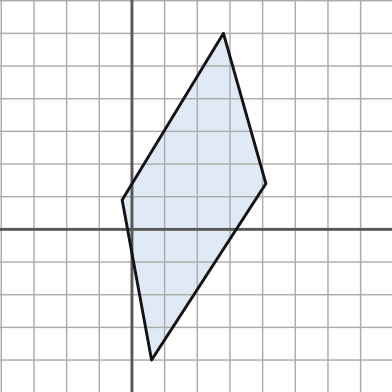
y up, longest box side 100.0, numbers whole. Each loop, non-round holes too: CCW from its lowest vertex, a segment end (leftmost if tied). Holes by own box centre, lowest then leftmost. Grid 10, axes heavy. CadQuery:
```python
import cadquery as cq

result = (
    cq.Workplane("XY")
    .moveTo(6.0, -40.0)
    .lineTo(41.0, 14.0)
    .lineTo(28.0, 60.0)
    .lineTo(-3.0, 9.0)
    .close()
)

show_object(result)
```